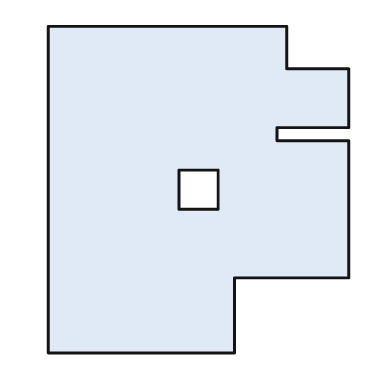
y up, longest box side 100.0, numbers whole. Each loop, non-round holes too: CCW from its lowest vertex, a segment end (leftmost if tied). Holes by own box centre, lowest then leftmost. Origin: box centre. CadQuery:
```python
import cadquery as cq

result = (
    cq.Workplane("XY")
    .moveTo(-46.0, -50.0)
    .lineTo(11.0, -50.0)
    .lineTo(11.0, -27.0)
    .lineTo(46.0, -27.0)
    .lineTo(46.0, 15.0)
    .lineTo(24.0, 15.0)
    .lineTo(24.0, 19.0)
    .lineTo(46.0, 19.0)
    .lineTo(46.0, 37.0)
    .lineTo(27.0, 37.0)
    .lineTo(27.0, 50.0)
    .lineTo(-46.0, 50.0)
    .close()
    .moveTo(-6.0, -6.0)
    .lineTo(6.0, -6.0)
    .lineTo(6.0, 6.0)
    .lineTo(-6.0, 6.0)
    .close()
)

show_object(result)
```